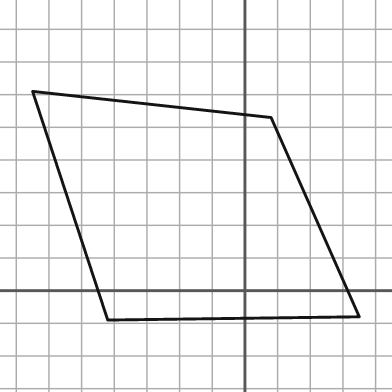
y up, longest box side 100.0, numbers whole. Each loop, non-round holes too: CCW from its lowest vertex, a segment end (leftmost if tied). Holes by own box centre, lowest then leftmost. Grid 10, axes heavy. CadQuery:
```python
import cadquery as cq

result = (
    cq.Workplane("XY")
    .moveTo(-42.0, -9.0)
    .lineTo(35.0, -8.0)
    .lineTo(8.0, 53.0)
    .lineTo(-65.0, 61.0)
    .close()
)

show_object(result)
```